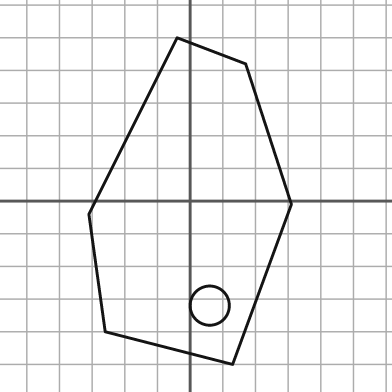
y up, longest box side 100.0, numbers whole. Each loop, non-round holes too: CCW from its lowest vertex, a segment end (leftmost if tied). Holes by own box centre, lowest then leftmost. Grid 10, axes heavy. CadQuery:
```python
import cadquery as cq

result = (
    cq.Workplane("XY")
    .moveTo(13.0, -50.0)
    .lineTo(31.0, -1.0)
    .lineTo(17.0, 42.0)
    .lineTo(-4.0, 50.0)
    .lineTo(-31.0, -4.0)
    .lineTo(-26.0, -40.0)
    .close()
    .moveTo(6.0, -32.0)
    .circle(6.0)
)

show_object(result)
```